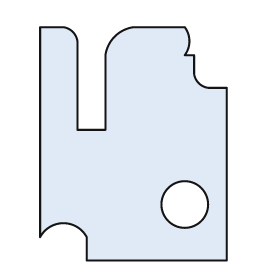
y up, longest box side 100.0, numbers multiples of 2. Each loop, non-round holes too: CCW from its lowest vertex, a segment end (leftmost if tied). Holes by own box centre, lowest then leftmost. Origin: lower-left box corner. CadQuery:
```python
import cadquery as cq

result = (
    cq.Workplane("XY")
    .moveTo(20.0, 0.0)
    .lineTo(80.0, 0.0)
    .lineTo(80.0, 74.0)
    .lineTo(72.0, 74.0)
    .threePointArc((68.0, 76.0), (66.0, 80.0))
    .lineTo(66.0, 88.0)
    .lineTo(62.0, 88.0)
    .threePointArc((64.0, 94.0), (62.0, 100.0))
    .lineTo(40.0, 100.0)
    .threePointArc((32.0, 96.0), (28.0, 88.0))
    .lineTo(28.0, 56.0)
    .lineTo(16.0, 56.0)
    .lineTo(16.0, 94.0)
    .threePointArc((14.0, 98.0), (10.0, 100.0))
    .lineTo(0.0, 100.0)
    .lineTo(0.0, 10.0)
    .threePointArc((10.0, 16.0), (20.0, 10.0))
    .close()
    .moveTo(62.0, 24.0)
    .circle(10.0)
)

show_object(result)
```